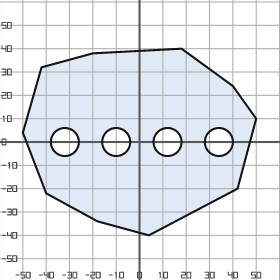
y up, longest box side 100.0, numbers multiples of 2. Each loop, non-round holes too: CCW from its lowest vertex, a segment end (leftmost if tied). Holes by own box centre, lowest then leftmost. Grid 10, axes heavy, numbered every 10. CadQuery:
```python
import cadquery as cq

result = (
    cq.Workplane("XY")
    .moveTo(4.0, -40.0)
    .lineTo(42.0, -20.0)
    .lineTo(50.0, 10.0)
    .lineTo(40.0, 24.0)
    .lineTo(18.0, 40.0)
    .lineTo(-20.0, 38.0)
    .lineTo(-42.0, 32.0)
    .lineTo(-50.0, 4.0)
    .lineTo(-40.0, -22.0)
    .lineTo(-18.0, -34.0)
    .close()
    .moveTo(-32.0, 0.0)
    .circle(6.0)
    .moveTo(-10.0, 0.0)
    .circle(6.0)
    .moveTo(12.0, 0.0)
    .circle(6.0)
    .moveTo(34.0, 0.0)
    .circle(6.0)
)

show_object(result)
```